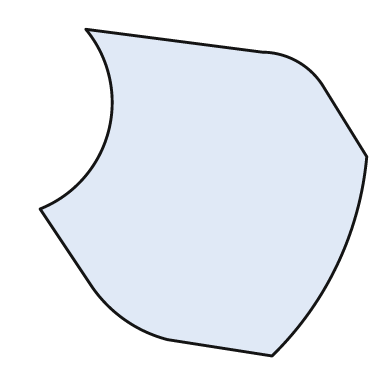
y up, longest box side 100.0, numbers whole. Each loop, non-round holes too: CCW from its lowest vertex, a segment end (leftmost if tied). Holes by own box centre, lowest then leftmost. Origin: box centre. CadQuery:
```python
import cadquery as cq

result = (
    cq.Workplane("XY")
    .moveTo(21.0, -50.0)
    .threePointArc((41.0, -22.0), (50.0, 11.0))
    .lineTo(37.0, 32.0)
    .threePointArc((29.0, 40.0), (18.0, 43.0))
    .lineTo(-36.0, 50.0)
    .threePointArc((-29.0, 19.0), (-50.0, -5.0))
    .lineTo(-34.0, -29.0)
    .threePointArc((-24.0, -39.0), (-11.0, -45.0))
    .close()
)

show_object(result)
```